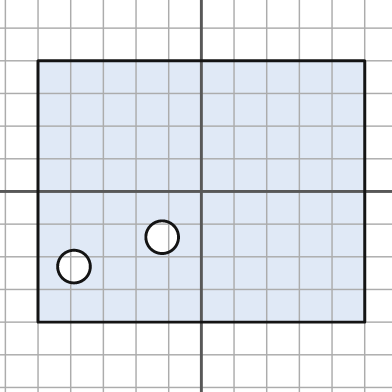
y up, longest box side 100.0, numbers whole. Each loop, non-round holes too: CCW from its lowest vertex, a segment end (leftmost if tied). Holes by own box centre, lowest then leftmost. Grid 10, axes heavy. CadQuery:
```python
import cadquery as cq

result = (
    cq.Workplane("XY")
    .moveTo(-50.0, -40.0)
    .lineTo(50.0, -40.0)
    .lineTo(50.0, 40.0)
    .lineTo(-50.0, 40.0)
    .close()
    .moveTo(-39.0, -23.0)
    .circle(5.0)
    .moveTo(-12.0, -14.0)
    .circle(5.0)
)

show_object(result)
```